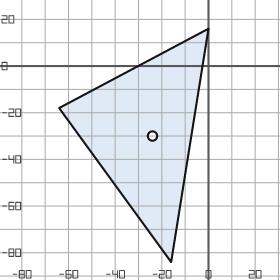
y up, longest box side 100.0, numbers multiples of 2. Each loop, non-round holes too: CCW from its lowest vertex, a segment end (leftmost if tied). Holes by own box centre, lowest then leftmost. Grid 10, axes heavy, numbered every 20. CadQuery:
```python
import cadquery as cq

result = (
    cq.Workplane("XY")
    .moveTo(-16.0, -84.0)
    .lineTo(0.0, 16.0)
    .lineTo(-64.0, -18.0)
    .close()
    .moveTo(-24.0, -30.0)
    .circle(2.0)
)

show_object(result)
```